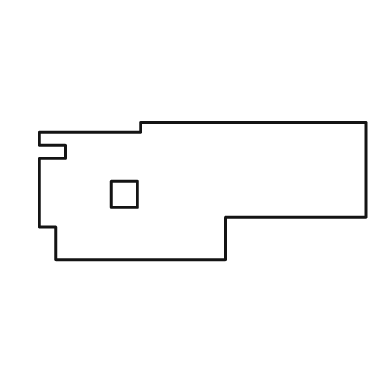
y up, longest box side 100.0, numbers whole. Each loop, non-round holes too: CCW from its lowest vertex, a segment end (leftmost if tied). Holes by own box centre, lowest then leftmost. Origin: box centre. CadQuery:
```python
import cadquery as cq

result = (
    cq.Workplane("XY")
    .moveTo(-45.0, -21.0)
    .lineTo(7.0, -21.0)
    .lineTo(7.0, -8.0)
    .lineTo(50.0, -8.0)
    .lineTo(50.0, 21.0)
    .lineTo(-19.0, 21.0)
    .lineTo(-19.0, 18.0)
    .lineTo(-50.0, 18.0)
    .lineTo(-50.0, 14.0)
    .lineTo(-42.0, 14.0)
    .lineTo(-42.0, 10.0)
    .lineTo(-50.0, 10.0)
    .lineTo(-50.0, -11.0)
    .lineTo(-45.0, -11.0)
    .close()
    .moveTo(-28.0, -5.0)
    .lineTo(-20.0, -5.0)
    .lineTo(-20.0, 3.0)
    .lineTo(-28.0, 3.0)
    .close()
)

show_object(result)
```